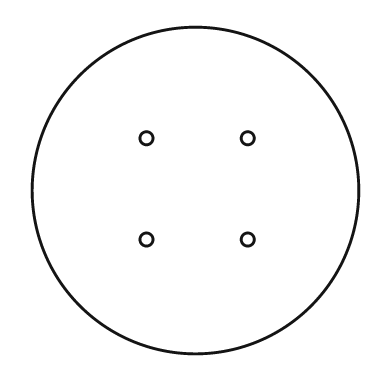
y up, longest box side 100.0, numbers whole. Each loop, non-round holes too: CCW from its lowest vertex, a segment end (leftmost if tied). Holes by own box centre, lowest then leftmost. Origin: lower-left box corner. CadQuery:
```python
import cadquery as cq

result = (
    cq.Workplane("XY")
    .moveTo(50.0, 50.0)
    .circle(50.0)
    .moveTo(35.0, 35.0)
    .circle(2.0)
    .moveTo(66.0, 35.0)
    .circle(2.0)
    .moveTo(35.0, 66.0)
    .circle(2.0)
    .moveTo(66.0, 66.0)
    .circle(2.0)
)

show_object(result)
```